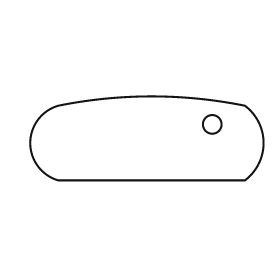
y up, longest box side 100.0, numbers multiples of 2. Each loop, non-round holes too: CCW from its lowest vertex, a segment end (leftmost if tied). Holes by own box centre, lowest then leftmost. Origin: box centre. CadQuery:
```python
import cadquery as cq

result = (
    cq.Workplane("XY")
    .moveTo(-38.0, -18.0)
    .lineTo(42.0, -18.0)
    .threePointArc((50.0, -2.0), (42.0, 14.0))
    .threePointArc((2.0, 18.0), (-38.0, 14.0))
    .threePointArc((-50.0, -2.0), (-38.0, -18.0))
    .close()
    .moveTo(28.0, 6.0)
    .circle(4.0)
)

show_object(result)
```